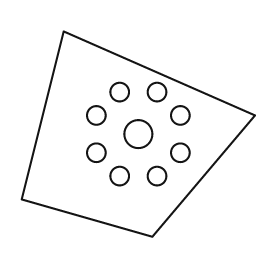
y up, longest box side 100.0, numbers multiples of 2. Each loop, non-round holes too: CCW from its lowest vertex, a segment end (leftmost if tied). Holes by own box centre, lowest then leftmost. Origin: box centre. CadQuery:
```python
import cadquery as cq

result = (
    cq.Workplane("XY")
    .moveTo(6.0, -44.0)
    .lineTo(50.0, 8.0)
    .lineTo(-32.0, 44.0)
    .lineTo(-50.0, -28.0)
    .close()
    .moveTo(-8.0, -18.0)
    .circle(4.0)
    .moveTo(8.0, -18.0)
    .circle(4.0)
    .moveTo(-18.0, -8.0)
    .circle(4.0)
    .moveTo(18.0, -8.0)
    .circle(4.0)
    .moveTo(0.0, 0.0)
    .circle(6.0)
    .moveTo(-18.0, 8.0)
    .circle(4.0)
    .moveTo(18.0, 8.0)
    .circle(4.0)
    .moveTo(-8.0, 18.0)
    .circle(4.0)
    .moveTo(8.0, 18.0)
    .circle(4.0)
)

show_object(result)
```